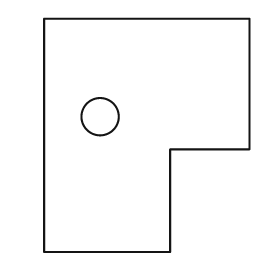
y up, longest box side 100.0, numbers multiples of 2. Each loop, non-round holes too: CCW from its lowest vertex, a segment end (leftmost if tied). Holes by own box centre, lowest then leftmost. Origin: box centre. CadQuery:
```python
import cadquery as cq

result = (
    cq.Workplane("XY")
    .moveTo(-44.0, -50.0)
    .lineTo(10.0, -50.0)
    .lineTo(10.0, -6.0)
    .lineTo(44.0, -6.0)
    .lineTo(44.0, 50.0)
    .lineTo(-44.0, 50.0)
    .close()
    .moveTo(-20.0, 8.0)
    .circle(8.0)
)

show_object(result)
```